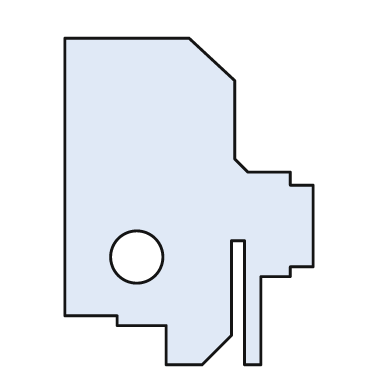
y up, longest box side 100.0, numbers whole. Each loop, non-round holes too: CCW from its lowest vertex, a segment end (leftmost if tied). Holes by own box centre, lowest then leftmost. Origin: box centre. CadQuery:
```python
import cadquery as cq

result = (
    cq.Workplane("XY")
    .moveTo(-7.0, -50.0)
    .lineTo(4.0, -50.0)
    .lineTo(13.0, -41.0)
    .lineTo(13.0, -12.0)
    .lineTo(17.0, -12.0)
    .lineTo(17.0, -50.0)
    .lineTo(22.0, -50.0)
    .lineTo(22.0, -23.0)
    .lineTo(31.0, -23.0)
    .lineTo(31.0, -20.0)
    .lineTo(38.0, -20.0)
    .lineTo(38.0, 5.0)
    .lineTo(31.0, 5.0)
    .lineTo(31.0, 9.0)
    .lineTo(18.0, 9.0)
    .lineTo(14.0, 13.0)
    .lineTo(14.0, 37.0)
    .lineTo(0.0, 50.0)
    .lineTo(-38.0, 50.0)
    .lineTo(-38.0, -35.0)
    .lineTo(-22.0, -35.0)
    .lineTo(-22.0, -38.0)
    .lineTo(-7.0, -38.0)
    .close()
    .moveTo(-16.0, -17.0)
    .circle(8.0)
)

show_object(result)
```